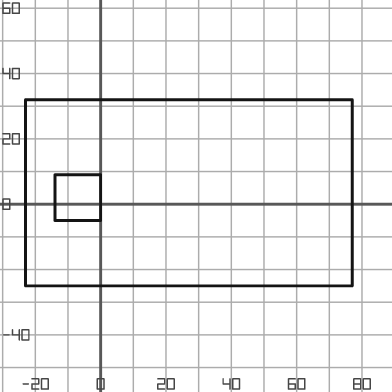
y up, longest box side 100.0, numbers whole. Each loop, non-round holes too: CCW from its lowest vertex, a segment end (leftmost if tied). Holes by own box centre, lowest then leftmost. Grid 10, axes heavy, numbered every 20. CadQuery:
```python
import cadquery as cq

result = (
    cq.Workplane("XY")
    .moveTo(-23.0, -25.0)
    .lineTo(77.0, -25.0)
    .lineTo(77.0, 32.0)
    .lineTo(-23.0, 32.0)
    .close()
    .moveTo(-14.0, -5.0)
    .lineTo(0.0, -5.0)
    .lineTo(0.0, 9.0)
    .lineTo(-14.0, 9.0)
    .close()
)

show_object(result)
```